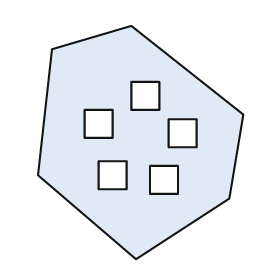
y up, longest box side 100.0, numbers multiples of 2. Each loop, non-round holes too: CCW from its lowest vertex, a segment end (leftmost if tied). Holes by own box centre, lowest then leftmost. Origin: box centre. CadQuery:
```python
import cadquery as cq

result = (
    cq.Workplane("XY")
    .moveTo(-2.0, -50.0)
    .lineTo(38.0, -24.0)
    .lineTo(44.0, 12.0)
    .lineTo(-4.0, 50.0)
    .lineTo(-38.0, 40.0)
    .lineTo(-44.0, -14.0)
    .close()
    .moveTo(4.0, -22.0)
    .lineTo(16.0, -22.0)
    .lineTo(16.0, -10.0)
    .lineTo(4.0, -10.0)
    .close()
    .moveTo(-18.0, -20.0)
    .lineTo(-6.0, -20.0)
    .lineTo(-6.0, -8.0)
    .lineTo(-18.0, -8.0)
    .close()
    .moveTo(12.0, -2.0)
    .lineTo(24.0, -2.0)
    .lineTo(24.0, 10.0)
    .lineTo(12.0, 10.0)
    .close()
    .moveTo(-24.0, 2.0)
    .lineTo(-12.0, 2.0)
    .lineTo(-12.0, 14.0)
    .lineTo(-24.0, 14.0)
    .close()
    .moveTo(-4.0, 14.0)
    .lineTo(8.0, 14.0)
    .lineTo(8.0, 26.0)
    .lineTo(-4.0, 26.0)
    .close()
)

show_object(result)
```